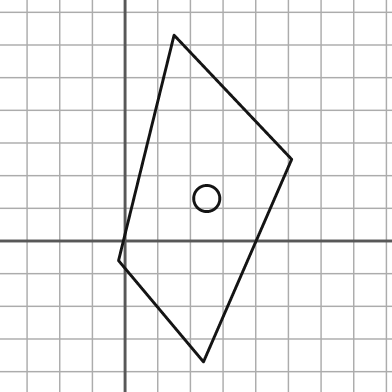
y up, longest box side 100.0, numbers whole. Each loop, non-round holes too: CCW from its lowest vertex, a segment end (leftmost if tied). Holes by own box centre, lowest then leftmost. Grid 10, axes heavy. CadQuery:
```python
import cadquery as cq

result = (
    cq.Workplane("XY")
    .moveTo(24.0, -37.0)
    .lineTo(51.0, 25.0)
    .lineTo(15.0, 63.0)
    .lineTo(-2.0, -6.0)
    .close()
    .moveTo(25.0, 13.0)
    .circle(4.0)
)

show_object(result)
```